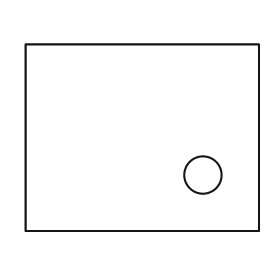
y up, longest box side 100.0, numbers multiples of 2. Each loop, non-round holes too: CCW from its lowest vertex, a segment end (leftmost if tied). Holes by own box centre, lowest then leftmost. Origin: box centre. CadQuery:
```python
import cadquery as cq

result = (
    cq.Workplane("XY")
    .moveTo(-50.0, -40.0)
    .lineTo(50.0, -40.0)
    .lineTo(50.0, 40.0)
    .lineTo(-50.0, 40.0)
    .close()
    .moveTo(26.0, -16.0)
    .circle(8.0)
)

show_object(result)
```